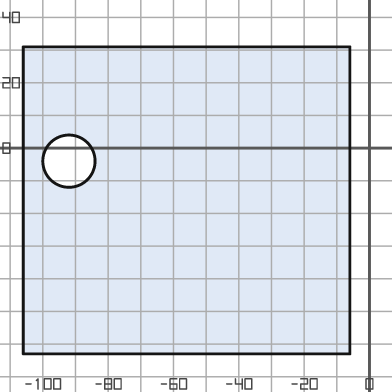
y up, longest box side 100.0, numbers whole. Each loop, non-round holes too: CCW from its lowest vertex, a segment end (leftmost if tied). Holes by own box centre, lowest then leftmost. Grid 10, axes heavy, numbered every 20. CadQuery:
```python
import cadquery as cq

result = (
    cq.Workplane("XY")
    .moveTo(-106.0, -63.0)
    .lineTo(-6.0, -63.0)
    .lineTo(-6.0, 31.0)
    .lineTo(-106.0, 31.0)
    .close()
    .moveTo(-92.0, -4.0)
    .circle(8.0)
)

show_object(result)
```